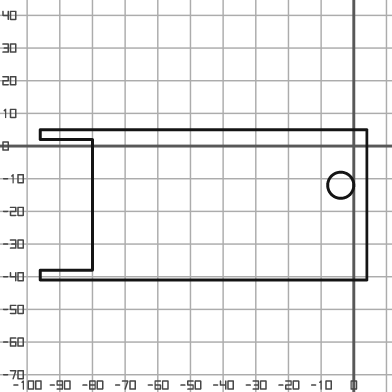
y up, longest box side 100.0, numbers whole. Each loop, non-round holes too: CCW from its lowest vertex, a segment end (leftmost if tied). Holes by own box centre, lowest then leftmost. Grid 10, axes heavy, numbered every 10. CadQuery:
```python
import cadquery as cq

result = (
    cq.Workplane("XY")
    .moveTo(-96.0, -41.0)
    .lineTo(4.0, -41.0)
    .lineTo(4.0, 5.0)
    .lineTo(-96.0, 5.0)
    .lineTo(-96.0, 2.0)
    .lineTo(-80.0, 2.0)
    .lineTo(-80.0, -38.0)
    .lineTo(-96.0, -38.0)
    .close()
    .moveTo(-4.0, -12.0)
    .circle(4.0)
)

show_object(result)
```